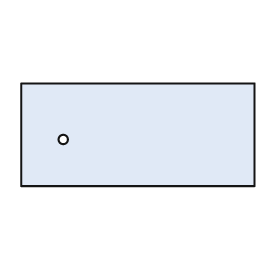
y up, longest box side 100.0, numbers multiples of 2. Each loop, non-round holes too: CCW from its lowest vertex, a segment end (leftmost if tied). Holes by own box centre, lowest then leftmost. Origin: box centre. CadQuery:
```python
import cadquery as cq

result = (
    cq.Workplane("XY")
    .moveTo(-50.0, -22.0)
    .lineTo(50.0, -22.0)
    .lineTo(50.0, 22.0)
    .lineTo(-50.0, 22.0)
    .close()
    .moveTo(-32.0, -2.0)
    .circle(2.0)
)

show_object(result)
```